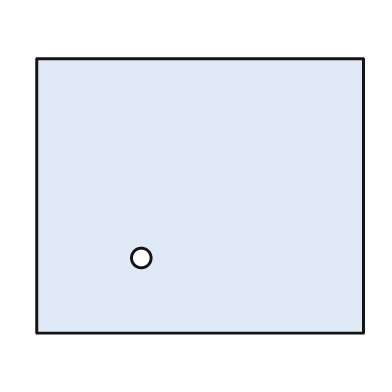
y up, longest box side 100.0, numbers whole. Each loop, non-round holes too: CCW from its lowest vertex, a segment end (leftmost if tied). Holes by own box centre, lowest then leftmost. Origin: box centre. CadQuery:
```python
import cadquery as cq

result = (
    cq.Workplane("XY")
    .moveTo(-50.0, -42.0)
    .lineTo(50.0, -42.0)
    .lineTo(50.0, 42.0)
    .lineTo(-50.0, 42.0)
    .close()
    .moveTo(-18.0, -19.0)
    .circle(3.0)
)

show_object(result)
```